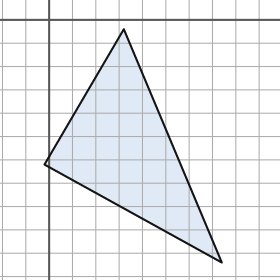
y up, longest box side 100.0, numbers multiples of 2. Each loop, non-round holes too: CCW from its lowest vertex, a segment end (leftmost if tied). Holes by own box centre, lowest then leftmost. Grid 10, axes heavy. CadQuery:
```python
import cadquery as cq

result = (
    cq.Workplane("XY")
    .moveTo(74.0, -104.0)
    .lineTo(32.0, -4.0)
    .lineTo(-2.0, -62.0)
    .close()
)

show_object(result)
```